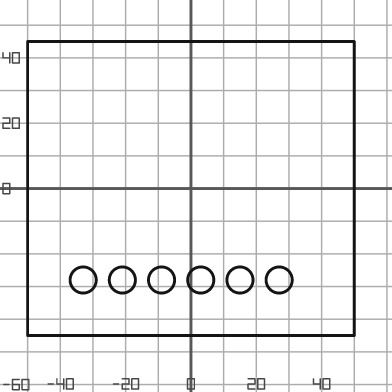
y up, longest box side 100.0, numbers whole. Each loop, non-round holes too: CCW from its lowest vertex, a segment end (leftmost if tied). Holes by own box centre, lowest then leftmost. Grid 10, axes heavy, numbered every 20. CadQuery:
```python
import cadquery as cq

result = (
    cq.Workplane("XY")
    .moveTo(-50.0, -45.0)
    .lineTo(50.0, -45.0)
    .lineTo(50.0, 45.0)
    .lineTo(-50.0, 45.0)
    .close()
    .moveTo(-33.0, -28.0)
    .circle(4.0)
    .moveTo(-21.0, -28.0)
    .circle(4.0)
    .moveTo(-9.0, -28.0)
    .circle(4.0)
    .moveTo(3.0, -28.0)
    .circle(4.0)
    .moveTo(15.0, -28.0)
    .circle(4.0)
    .moveTo(27.0, -28.0)
    .circle(4.0)
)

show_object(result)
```